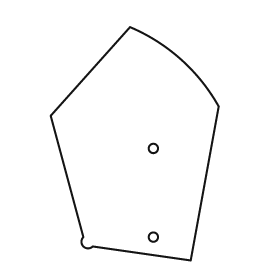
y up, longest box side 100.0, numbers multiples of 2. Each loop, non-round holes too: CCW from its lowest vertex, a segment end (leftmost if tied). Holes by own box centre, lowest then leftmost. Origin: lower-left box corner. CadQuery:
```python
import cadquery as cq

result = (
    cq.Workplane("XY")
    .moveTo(60.0, 0.0)
    .lineTo(72.0, 66.0)
    .threePointArc((56.0, 86.0), (34.0, 100.0))
    .lineTo(0.0, 62.0)
    .lineTo(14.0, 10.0)
    .threePointArc((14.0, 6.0), (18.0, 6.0))
    .close()
    .moveTo(44.0, 10.0)
    .circle(2.0)
    .moveTo(44.0, 48.0)
    .circle(2.0)
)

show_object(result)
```